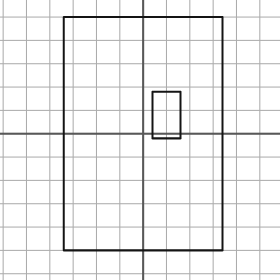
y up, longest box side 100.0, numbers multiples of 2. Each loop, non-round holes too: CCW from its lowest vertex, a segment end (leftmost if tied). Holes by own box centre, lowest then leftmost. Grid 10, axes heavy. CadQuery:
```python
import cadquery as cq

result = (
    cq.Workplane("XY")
    .moveTo(-34.0, -50.0)
    .lineTo(34.0, -50.0)
    .lineTo(34.0, 50.0)
    .lineTo(-34.0, 50.0)
    .close()
    .moveTo(4.0, -2.0)
    .lineTo(16.0, -2.0)
    .lineTo(16.0, 18.0)
    .lineTo(4.0, 18.0)
    .close()
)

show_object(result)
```